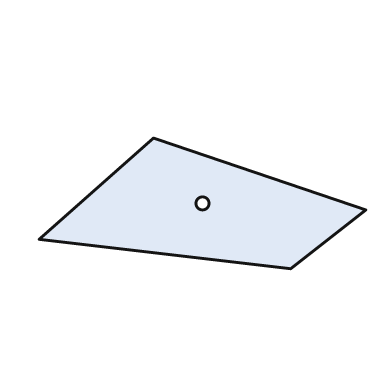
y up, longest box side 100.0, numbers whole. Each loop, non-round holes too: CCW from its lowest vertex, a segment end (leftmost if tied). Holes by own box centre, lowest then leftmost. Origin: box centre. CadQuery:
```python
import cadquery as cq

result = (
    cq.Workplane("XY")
    .moveTo(27.0, -20.0)
    .lineTo(50.0, -2.0)
    .lineTo(-15.0, 20.0)
    .lineTo(-50.0, -11.0)
    .close()
    .moveTo(0.0, 0.0)
    .circle(2.0)
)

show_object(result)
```